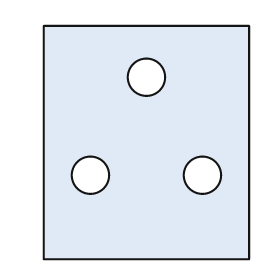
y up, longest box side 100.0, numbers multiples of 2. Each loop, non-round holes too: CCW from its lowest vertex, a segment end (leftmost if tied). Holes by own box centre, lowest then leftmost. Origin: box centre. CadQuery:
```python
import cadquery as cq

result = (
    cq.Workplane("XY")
    .moveTo(-44.0, -50.0)
    .lineTo(44.0, -50.0)
    .lineTo(44.0, 50.0)
    .lineTo(-44.0, 50.0)
    .close()
    .moveTo(-24.0, -14.0)
    .circle(8.0)
    .moveTo(24.0, -14.0)
    .circle(8.0)
    .moveTo(0.0, 28.0)
    .circle(8.0)
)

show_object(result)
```